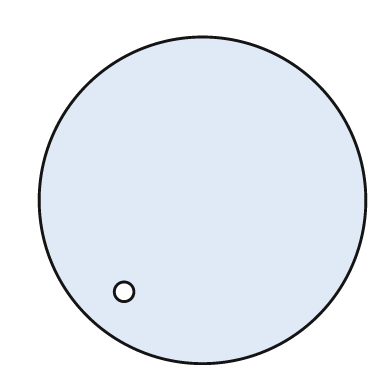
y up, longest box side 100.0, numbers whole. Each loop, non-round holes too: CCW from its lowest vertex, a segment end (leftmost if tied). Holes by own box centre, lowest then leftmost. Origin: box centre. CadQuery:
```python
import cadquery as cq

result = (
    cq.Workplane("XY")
    .moveTo(0.0, 0.0)
    .circle(50.0)
    .moveTo(-24.0, -28.0)
    .circle(3.0)
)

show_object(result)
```